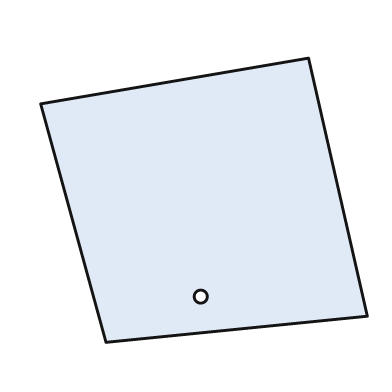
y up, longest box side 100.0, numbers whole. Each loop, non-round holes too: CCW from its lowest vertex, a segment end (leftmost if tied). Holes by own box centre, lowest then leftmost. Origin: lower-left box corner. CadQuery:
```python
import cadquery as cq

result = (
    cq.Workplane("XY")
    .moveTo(20.0, 0.0)
    .lineTo(100.0, 8.0)
    .lineTo(82.0, 87.0)
    .lineTo(0.0, 73.0)
    .close()
    .moveTo(49.0, 14.0)
    .circle(2.0)
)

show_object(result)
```